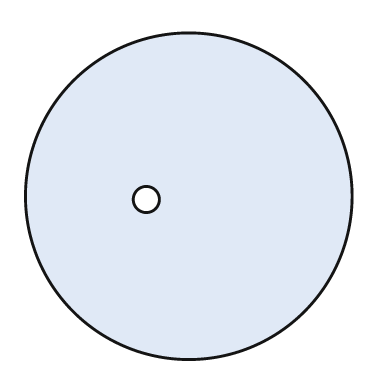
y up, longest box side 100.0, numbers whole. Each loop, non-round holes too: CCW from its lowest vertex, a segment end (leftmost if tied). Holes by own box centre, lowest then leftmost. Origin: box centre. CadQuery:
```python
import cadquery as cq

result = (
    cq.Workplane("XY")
    .moveTo(0.0, 0.0)
    .circle(50.0)
    .moveTo(-13.0, -1.0)
    .circle(4.0)
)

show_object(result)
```